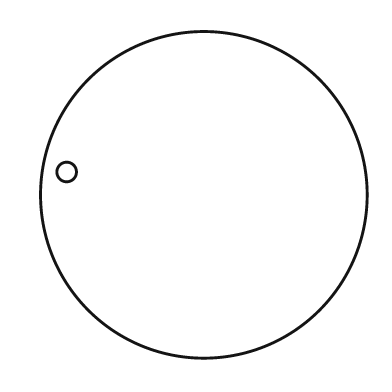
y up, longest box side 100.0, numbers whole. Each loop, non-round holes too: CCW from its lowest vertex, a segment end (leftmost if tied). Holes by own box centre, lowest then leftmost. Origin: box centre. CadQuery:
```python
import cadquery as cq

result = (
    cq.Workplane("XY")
    .moveTo(0.0, 0.0)
    .circle(50.0)
    .moveTo(-42.0, 7.0)
    .circle(3.0)
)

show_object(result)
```